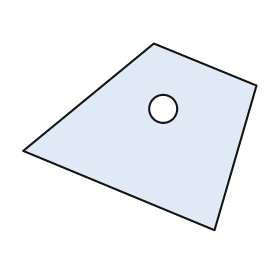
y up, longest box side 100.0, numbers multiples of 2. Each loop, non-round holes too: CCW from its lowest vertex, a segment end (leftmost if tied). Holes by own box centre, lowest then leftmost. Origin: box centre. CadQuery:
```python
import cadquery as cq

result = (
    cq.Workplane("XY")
    .moveTo(32.0, -40.0)
    .lineTo(50.0, 22.0)
    .lineTo(6.0, 40.0)
    .lineTo(-50.0, -6.0)
    .close()
    .moveTo(10.0, 12.0)
    .circle(6.0)
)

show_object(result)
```